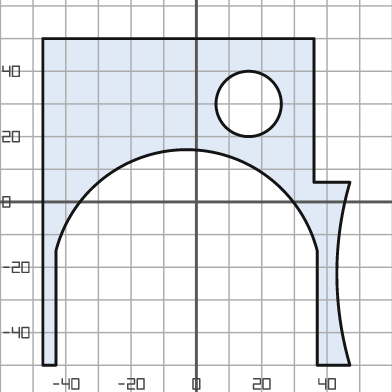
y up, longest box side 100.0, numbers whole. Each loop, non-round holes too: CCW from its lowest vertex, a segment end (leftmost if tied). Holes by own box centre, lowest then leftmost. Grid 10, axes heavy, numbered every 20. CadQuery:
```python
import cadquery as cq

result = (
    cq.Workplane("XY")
    .moveTo(-47.0, -50.0)
    .lineTo(-43.0, -50.0)
    .lineTo(-43.0, -15.0)
    .threePointArc((-3.0, 16.0), (37.0, -15.0))
    .lineTo(37.0, -50.0)
    .lineTo(47.0, -50.0)
    .threePointArc((43.0, -22.0), (47.0, 6.0))
    .lineTo(36.0, 6.0)
    .lineTo(36.0, 50.0)
    .lineTo(-47.0, 50.0)
    .close()
    .moveTo(16.0, 30.0)
    .circle(10.0)
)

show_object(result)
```